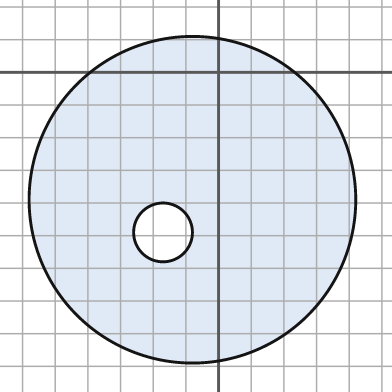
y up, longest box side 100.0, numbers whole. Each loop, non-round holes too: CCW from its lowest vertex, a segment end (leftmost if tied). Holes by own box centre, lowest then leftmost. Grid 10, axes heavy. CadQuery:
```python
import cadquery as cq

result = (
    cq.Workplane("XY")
    .moveTo(-8.0, -39.0)
    .circle(50.0)
    .moveTo(-17.0, -49.0)
    .circle(9.0)
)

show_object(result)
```